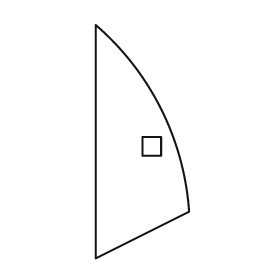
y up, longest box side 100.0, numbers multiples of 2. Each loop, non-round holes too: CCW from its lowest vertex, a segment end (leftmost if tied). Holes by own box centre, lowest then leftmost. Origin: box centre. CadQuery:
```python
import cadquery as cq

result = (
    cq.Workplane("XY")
    .moveTo(-20.0, -50.0)
    .lineTo(20.0, -30.0)
    .threePointArc((8.0, 14.0), (-20.0, 50.0))
    .close()
    .moveTo(0.0, -6.0)
    .lineTo(8.0, -6.0)
    .lineTo(8.0, 2.0)
    .lineTo(0.0, 2.0)
    .close()
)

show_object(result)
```